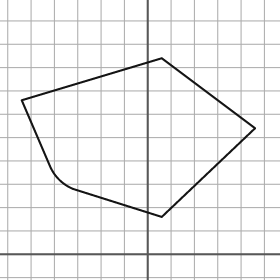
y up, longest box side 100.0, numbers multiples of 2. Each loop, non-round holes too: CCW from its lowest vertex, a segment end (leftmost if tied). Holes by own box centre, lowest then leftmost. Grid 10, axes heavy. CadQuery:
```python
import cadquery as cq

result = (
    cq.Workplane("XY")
    .moveTo(6.0, 16.0)
    .lineTo(46.0, 54.0)
    .lineTo(6.0, 84.0)
    .lineTo(-54.0, 66.0)
    .lineTo(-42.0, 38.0)
    .threePointArc((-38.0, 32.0), (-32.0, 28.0))
    .close()
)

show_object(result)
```